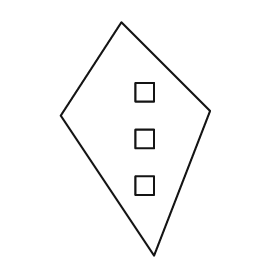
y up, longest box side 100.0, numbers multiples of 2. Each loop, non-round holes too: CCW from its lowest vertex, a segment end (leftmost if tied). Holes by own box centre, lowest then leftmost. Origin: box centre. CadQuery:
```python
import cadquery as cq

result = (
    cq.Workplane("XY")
    .moveTo(8.0, -50.0)
    .lineTo(32.0, 12.0)
    .lineTo(-6.0, 50.0)
    .lineTo(-32.0, 10.0)
    .close()
    .moveTo(0.0, -24.0)
    .lineTo(8.0, -24.0)
    .lineTo(8.0, -16.0)
    .lineTo(0.0, -16.0)
    .close()
    .moveTo(0.0, -4.0)
    .lineTo(8.0, -4.0)
    .lineTo(8.0, 4.0)
    .lineTo(0.0, 4.0)
    .close()
    .moveTo(0.0, 16.0)
    .lineTo(8.0, 16.0)
    .lineTo(8.0, 24.0)
    .lineTo(0.0, 24.0)
    .close()
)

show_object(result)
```